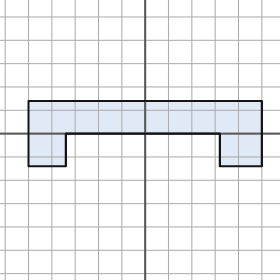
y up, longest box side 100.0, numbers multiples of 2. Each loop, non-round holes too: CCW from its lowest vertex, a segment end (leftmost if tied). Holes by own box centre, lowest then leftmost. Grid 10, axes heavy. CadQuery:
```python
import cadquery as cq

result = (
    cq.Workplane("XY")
    .moveTo(-50.0, -14.0)
    .lineTo(-34.0, -14.0)
    .lineTo(-34.0, 0.0)
    .lineTo(32.0, 0.0)
    .lineTo(32.0, -14.0)
    .lineTo(50.0, -14.0)
    .lineTo(50.0, 14.0)
    .lineTo(-50.0, 14.0)
    .close()
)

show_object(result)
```